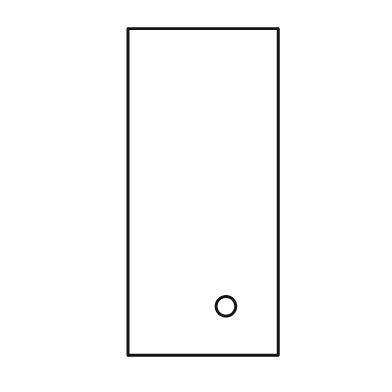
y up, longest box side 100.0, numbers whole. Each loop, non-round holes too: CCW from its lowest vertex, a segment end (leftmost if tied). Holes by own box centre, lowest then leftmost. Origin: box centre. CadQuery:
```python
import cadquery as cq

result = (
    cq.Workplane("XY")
    .moveTo(-23.0, -50.0)
    .lineTo(23.0, -50.0)
    .lineTo(23.0, 50.0)
    .lineTo(-23.0, 50.0)
    .close()
    .moveTo(7.0, -35.0)
    .circle(3.0)
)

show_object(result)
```